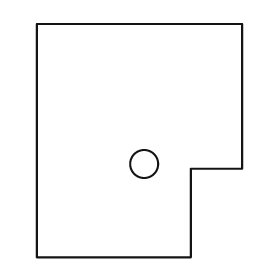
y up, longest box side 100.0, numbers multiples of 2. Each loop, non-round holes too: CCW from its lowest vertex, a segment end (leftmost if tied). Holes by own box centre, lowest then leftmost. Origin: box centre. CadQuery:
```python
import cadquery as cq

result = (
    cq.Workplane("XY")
    .moveTo(-44.0, -50.0)
    .lineTo(22.0, -50.0)
    .lineTo(22.0, -12.0)
    .lineTo(44.0, -12.0)
    .lineTo(44.0, 50.0)
    .lineTo(-44.0, 50.0)
    .close()
    .moveTo(2.0, -10.0)
    .circle(6.0)
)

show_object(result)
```